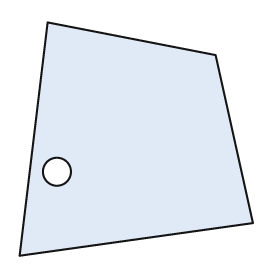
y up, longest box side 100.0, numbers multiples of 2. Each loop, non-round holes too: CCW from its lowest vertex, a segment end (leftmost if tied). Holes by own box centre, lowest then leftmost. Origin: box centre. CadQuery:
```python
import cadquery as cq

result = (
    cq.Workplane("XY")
    .moveTo(-50.0, -50.0)
    .lineTo(50.0, -36.0)
    .lineTo(34.0, 36.0)
    .lineTo(-38.0, 50.0)
    .close()
    .moveTo(-34.0, -14.0)
    .circle(6.0)
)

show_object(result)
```